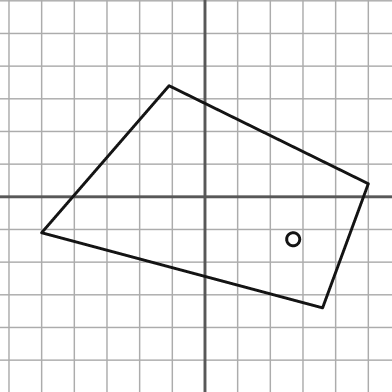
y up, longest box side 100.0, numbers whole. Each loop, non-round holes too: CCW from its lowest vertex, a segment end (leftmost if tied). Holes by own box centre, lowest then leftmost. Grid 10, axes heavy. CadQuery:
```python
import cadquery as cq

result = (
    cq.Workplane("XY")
    .moveTo(36.0, -34.0)
    .lineTo(50.0, 4.0)
    .lineTo(-11.0, 34.0)
    .lineTo(-50.0, -11.0)
    .close()
    .moveTo(27.0, -13.0)
    .circle(2.0)
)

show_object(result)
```